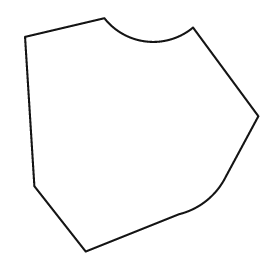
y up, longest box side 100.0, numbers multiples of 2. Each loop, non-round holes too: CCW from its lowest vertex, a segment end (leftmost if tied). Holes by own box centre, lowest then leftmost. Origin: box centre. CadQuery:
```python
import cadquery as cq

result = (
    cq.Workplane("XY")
    .moveTo(-24.0, -50.0)
    .lineTo(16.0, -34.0)
    .threePointArc((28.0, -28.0), (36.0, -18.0))
    .lineTo(50.0, 8.0)
    .lineTo(22.0, 46.0)
    .threePointArc((2.0, 40.0), (-16.0, 50.0))
    .lineTo(-50.0, 42.0)
    .lineTo(-46.0, -22.0)
    .close()
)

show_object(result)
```